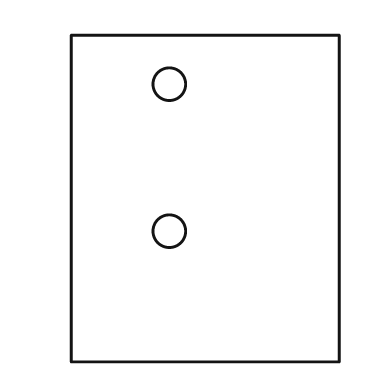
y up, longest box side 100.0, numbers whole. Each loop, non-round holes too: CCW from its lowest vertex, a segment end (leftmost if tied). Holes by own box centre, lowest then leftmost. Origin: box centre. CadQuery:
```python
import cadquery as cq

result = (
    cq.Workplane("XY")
    .moveTo(-41.0, -50.0)
    .lineTo(41.0, -50.0)
    .lineTo(41.0, 50.0)
    .lineTo(-41.0, 50.0)
    .close()
    .moveTo(-11.0, -10.0)
    .circle(5.0)
    .moveTo(-11.0, 35.0)
    .circle(5.0)
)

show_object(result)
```